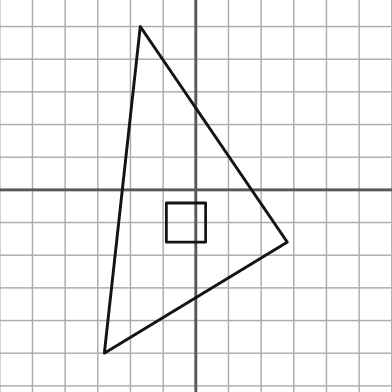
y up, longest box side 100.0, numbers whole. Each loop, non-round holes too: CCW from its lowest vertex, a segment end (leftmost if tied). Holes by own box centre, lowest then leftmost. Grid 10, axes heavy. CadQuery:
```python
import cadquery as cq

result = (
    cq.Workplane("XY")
    .moveTo(-28.0, -50.0)
    .lineTo(28.0, -16.0)
    .lineTo(-17.0, 50.0)
    .close()
    .moveTo(-9.0, -16.0)
    .lineTo(3.0, -16.0)
    .lineTo(3.0, -4.0)
    .lineTo(-9.0, -4.0)
    .close()
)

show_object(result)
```